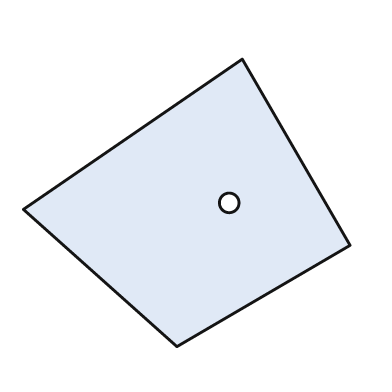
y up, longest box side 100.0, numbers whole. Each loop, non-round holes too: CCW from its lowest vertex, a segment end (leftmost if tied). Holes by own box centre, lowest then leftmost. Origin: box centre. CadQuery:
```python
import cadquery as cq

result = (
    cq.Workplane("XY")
    .moveTo(-3.0, -44.0)
    .lineTo(50.0, -13.0)
    .lineTo(17.0, 44.0)
    .lineTo(-50.0, -2.0)
    .close()
    .moveTo(13.0, 0.0)
    .circle(3.0)
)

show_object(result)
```